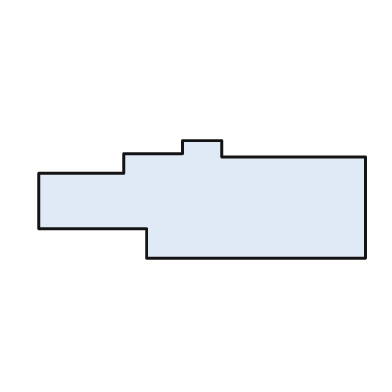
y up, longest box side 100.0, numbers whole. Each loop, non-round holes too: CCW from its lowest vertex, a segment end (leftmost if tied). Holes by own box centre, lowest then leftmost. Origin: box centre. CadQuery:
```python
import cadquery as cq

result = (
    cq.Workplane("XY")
    .moveTo(-17.0, -18.0)
    .lineTo(50.0, -18.0)
    .lineTo(50.0, 13.0)
    .lineTo(6.0, 13.0)
    .lineTo(6.0, 18.0)
    .lineTo(-6.0, 18.0)
    .lineTo(-6.0, 14.0)
    .lineTo(-24.0, 14.0)
    .lineTo(-24.0, 8.0)
    .lineTo(-50.0, 8.0)
    .lineTo(-50.0, -9.0)
    .lineTo(-17.0, -9.0)
    .close()
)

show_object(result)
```